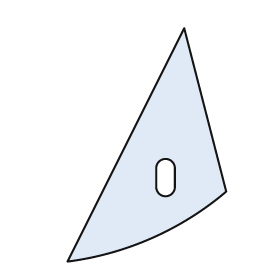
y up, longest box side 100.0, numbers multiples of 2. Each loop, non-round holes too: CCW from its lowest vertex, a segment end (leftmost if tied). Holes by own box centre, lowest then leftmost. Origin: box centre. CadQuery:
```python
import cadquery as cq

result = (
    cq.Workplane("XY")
    .moveTo(-34.0, -50.0)
    .threePointArc((2.0, -40.0), (34.0, -20.0))
    .lineTo(16.0, 50.0)
    .close()
    .moveTo(4.0, -18.0)
    .threePointArc((8.0, -22.0), (12.0, -18.0))
    .lineTo(12.0, -10.0)
    .threePointArc((8.0, -6.0), (4.0, -10.0))
    .close()
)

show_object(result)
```